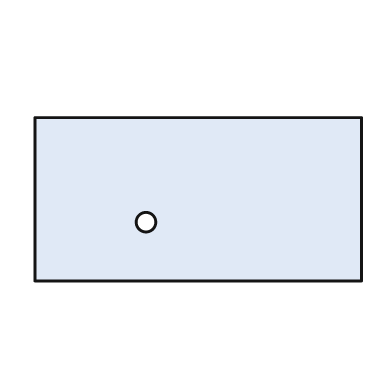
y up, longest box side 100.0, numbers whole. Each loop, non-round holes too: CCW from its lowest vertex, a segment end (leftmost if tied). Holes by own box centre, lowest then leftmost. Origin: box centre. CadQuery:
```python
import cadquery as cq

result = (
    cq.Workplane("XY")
    .moveTo(-50.0, -25.0)
    .lineTo(50.0, -25.0)
    .lineTo(50.0, 25.0)
    .lineTo(-50.0, 25.0)
    .close()
    .moveTo(-16.0, -7.0)
    .circle(3.0)
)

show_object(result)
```